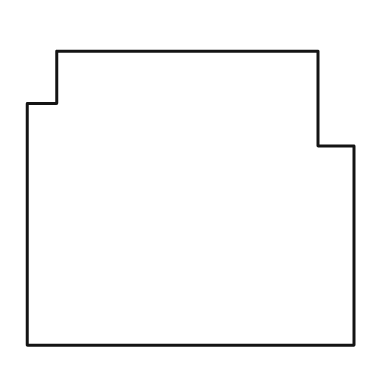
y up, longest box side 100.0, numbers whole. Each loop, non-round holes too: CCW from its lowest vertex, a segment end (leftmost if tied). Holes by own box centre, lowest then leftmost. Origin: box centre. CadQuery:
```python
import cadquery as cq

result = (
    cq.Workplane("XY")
    .moveTo(-50.0, -45.0)
    .lineTo(50.0, -45.0)
    .lineTo(50.0, 16.0)
    .lineTo(39.0, 16.0)
    .lineTo(39.0, 45.0)
    .lineTo(-41.0, 45.0)
    .lineTo(-41.0, 29.0)
    .lineTo(-50.0, 29.0)
    .close()
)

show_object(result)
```